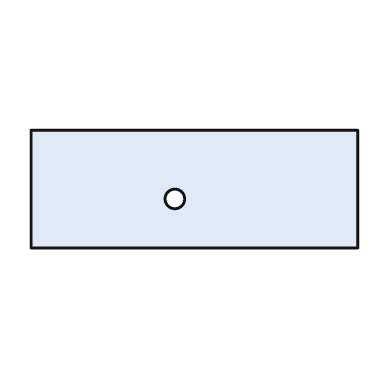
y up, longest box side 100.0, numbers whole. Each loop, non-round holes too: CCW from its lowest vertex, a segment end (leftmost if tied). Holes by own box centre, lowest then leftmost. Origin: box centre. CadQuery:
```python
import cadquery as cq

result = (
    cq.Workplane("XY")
    .moveTo(-50.0, -18.0)
    .lineTo(50.0, -18.0)
    .lineTo(50.0, 18.0)
    .lineTo(-50.0, 18.0)
    .close()
    .moveTo(-6.0, -3.0)
    .circle(3.0)
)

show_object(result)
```